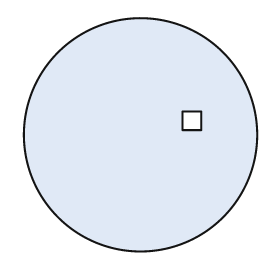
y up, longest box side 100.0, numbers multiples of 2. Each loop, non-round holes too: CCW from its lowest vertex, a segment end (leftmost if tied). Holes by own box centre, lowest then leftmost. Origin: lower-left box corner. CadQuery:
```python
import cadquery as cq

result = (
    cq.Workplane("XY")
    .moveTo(50.0, 50.0)
    .circle(50.0)
    .moveTo(68.0, 52.0)
    .lineTo(76.0, 52.0)
    .lineTo(76.0, 60.0)
    .lineTo(68.0, 60.0)
    .close()
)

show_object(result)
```